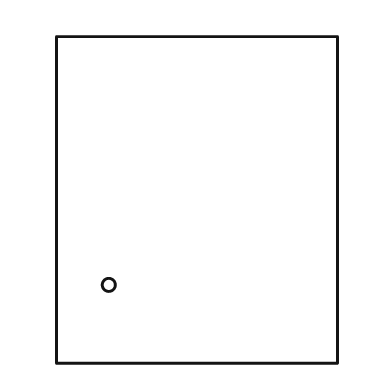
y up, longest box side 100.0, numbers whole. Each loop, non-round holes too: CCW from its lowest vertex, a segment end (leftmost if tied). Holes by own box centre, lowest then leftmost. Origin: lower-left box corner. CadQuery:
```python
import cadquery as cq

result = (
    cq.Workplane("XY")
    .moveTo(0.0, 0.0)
    .lineTo(86.0, 0.0)
    .lineTo(86.0, 100.0)
    .lineTo(0.0, 100.0)
    .close()
    .moveTo(16.0, 24.0)
    .circle(2.0)
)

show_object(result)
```